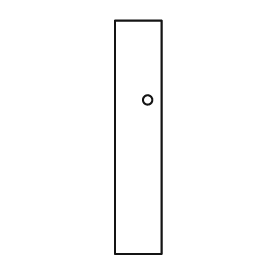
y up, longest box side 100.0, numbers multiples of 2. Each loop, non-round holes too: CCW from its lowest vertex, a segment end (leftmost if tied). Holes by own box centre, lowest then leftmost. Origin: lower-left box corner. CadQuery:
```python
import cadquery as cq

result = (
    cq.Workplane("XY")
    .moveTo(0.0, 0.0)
    .lineTo(20.0, 0.0)
    .lineTo(20.0, 100.0)
    .lineTo(0.0, 100.0)
    .close()
    .moveTo(14.0, 66.0)
    .circle(2.0)
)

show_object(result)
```